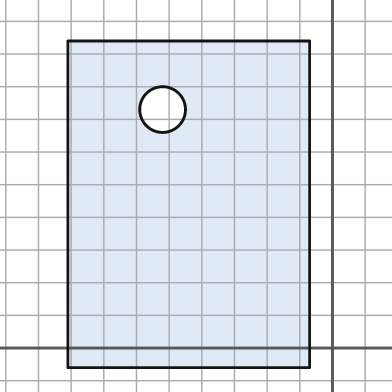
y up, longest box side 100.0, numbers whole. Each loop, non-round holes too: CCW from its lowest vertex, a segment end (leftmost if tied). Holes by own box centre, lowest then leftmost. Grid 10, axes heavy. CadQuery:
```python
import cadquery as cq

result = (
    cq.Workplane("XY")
    .moveTo(-81.0, -6.0)
    .lineTo(-7.0, -6.0)
    .lineTo(-7.0, 94.0)
    .lineTo(-81.0, 94.0)
    .close()
    .moveTo(-52.0, 73.0)
    .circle(7.0)
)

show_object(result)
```